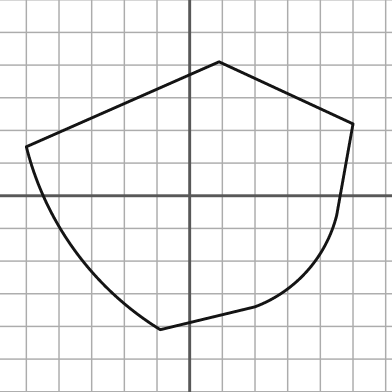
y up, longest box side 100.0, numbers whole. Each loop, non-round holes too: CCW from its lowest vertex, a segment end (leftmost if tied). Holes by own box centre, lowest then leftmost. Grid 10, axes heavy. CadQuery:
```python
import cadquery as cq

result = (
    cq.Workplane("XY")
    .moveTo(-9.0, -41.0)
    .lineTo(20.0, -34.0)
    .threePointArc((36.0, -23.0), (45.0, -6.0))
    .lineTo(50.0, 22.0)
    .lineTo(9.0, 41.0)
    .lineTo(-50.0, 15.0)
    .threePointArc((-35.0, -17.0), (-9.0, -41.0))
    .close()
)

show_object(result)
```